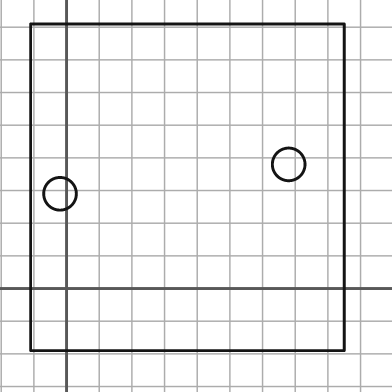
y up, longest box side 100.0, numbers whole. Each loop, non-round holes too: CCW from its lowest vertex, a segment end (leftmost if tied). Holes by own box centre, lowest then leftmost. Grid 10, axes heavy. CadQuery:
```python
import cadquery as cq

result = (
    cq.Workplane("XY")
    .moveTo(-11.0, -19.0)
    .lineTo(85.0, -19.0)
    .lineTo(85.0, 81.0)
    .lineTo(-11.0, 81.0)
    .close()
    .moveTo(-2.0, 29.0)
    .circle(5.0)
    .moveTo(68.0, 38.0)
    .circle(5.0)
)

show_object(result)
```